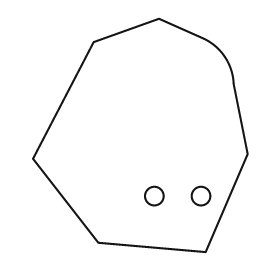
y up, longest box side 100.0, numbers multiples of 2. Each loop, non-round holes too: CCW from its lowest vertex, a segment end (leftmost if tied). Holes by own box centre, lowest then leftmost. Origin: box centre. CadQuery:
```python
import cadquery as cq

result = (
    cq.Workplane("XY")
    .moveTo(28.0, -50.0)
    .lineTo(46.0, -8.0)
    .lineTo(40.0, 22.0)
    .threePointArc((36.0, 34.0), (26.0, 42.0))
    .lineTo(8.0, 50.0)
    .lineTo(-20.0, 40.0)
    .lineTo(-46.0, -10.0)
    .lineTo(-18.0, -46.0)
    .close()
    .moveTo(6.0, -26.0)
    .circle(4.0)
    .moveTo(26.0, -26.0)
    .circle(4.0)
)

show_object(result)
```